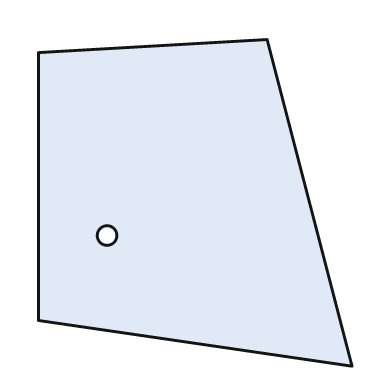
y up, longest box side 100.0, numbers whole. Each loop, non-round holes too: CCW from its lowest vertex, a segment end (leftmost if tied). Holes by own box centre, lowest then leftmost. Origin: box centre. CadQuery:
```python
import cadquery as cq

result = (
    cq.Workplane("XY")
    .moveTo(48.0, -50.0)
    .lineTo(22.0, 50.0)
    .lineTo(-48.0, 46.0)
    .lineTo(-48.0, -36.0)
    .close()
    .moveTo(-27.0, -10.0)
    .circle(3.0)
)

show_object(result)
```